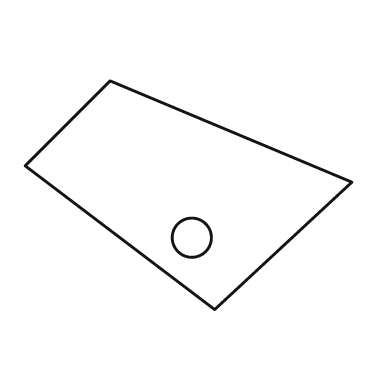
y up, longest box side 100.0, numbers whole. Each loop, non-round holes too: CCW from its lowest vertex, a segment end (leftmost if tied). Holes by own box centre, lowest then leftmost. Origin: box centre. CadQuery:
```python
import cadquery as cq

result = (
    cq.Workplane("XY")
    .moveTo(8.0, -35.0)
    .lineTo(50.0, 4.0)
    .lineTo(-24.0, 35.0)
    .lineTo(-50.0, 9.0)
    .close()
    .moveTo(1.0, -13.0)
    .circle(6.0)
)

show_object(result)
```